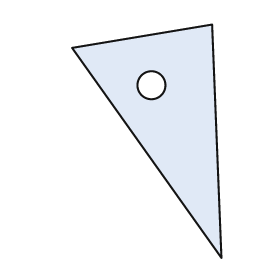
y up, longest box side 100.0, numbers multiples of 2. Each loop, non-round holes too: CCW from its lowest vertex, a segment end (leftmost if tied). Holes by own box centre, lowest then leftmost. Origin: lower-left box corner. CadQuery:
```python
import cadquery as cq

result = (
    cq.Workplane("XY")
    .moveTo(64.0, 0.0)
    .lineTo(60.0, 100.0)
    .lineTo(0.0, 90.0)
    .close()
    .moveTo(34.0, 74.0)
    .circle(6.0)
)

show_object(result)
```